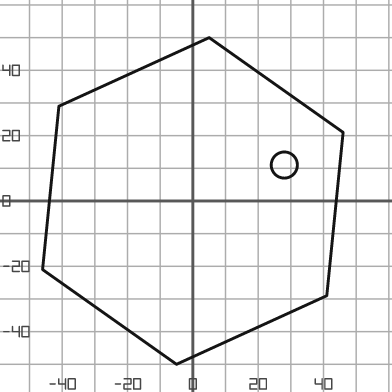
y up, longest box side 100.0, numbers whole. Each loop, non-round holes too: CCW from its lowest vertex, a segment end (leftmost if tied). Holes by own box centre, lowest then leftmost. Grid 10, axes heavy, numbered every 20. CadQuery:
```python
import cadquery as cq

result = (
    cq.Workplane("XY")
    .moveTo(-5.0, -50.0)
    .lineTo(41.0, -29.0)
    .lineTo(46.0, 21.0)
    .lineTo(5.0, 50.0)
    .lineTo(-41.0, 29.0)
    .lineTo(-46.0, -21.0)
    .close()
    .moveTo(28.0, 11.0)
    .circle(4.0)
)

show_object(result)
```